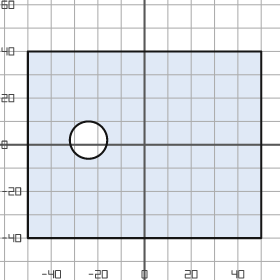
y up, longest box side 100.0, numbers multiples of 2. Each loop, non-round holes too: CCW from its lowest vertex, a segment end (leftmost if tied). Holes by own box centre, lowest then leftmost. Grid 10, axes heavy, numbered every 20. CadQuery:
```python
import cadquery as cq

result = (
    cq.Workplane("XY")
    .moveTo(-50.0, -40.0)
    .lineTo(50.0, -40.0)
    .lineTo(50.0, 40.0)
    .lineTo(-50.0, 40.0)
    .close()
    .moveTo(-24.0, 2.0)
    .circle(8.0)
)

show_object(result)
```